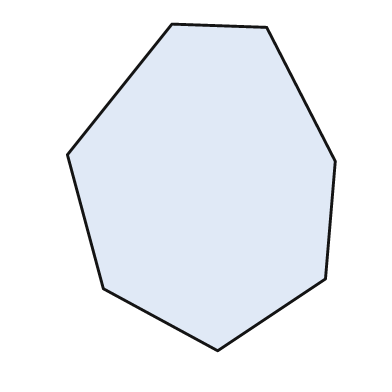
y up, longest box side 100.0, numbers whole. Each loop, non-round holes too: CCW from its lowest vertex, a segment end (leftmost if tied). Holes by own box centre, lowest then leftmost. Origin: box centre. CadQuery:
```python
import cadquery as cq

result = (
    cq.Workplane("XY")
    .moveTo(5.0, -50.0)
    .lineTo(38.0, -28.0)
    .lineTo(41.0, 8.0)
    .lineTo(20.0, 49.0)
    .lineTo(-9.0, 50.0)
    .lineTo(-41.0, 10.0)
    .lineTo(-30.0, -31.0)
    .close()
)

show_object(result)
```